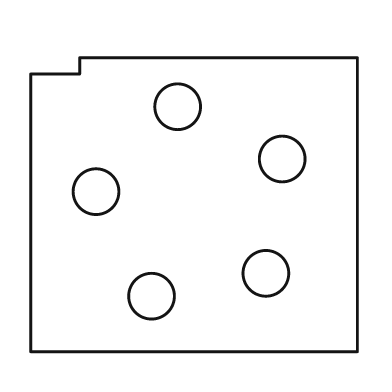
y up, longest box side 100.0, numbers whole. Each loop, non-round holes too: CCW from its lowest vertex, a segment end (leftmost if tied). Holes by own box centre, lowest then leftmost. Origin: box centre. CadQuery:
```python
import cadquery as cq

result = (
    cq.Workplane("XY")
    .moveTo(-50.0, -45.0)
    .lineTo(50.0, -45.0)
    .lineTo(50.0, 45.0)
    .lineTo(-35.0, 45.0)
    .lineTo(-35.0, 40.0)
    .lineTo(-50.0, 40.0)
    .close()
    .moveTo(-13.0, -28.0)
    .circle(7.0)
    .moveTo(22.0, -21.0)
    .circle(7.0)
    .moveTo(-30.0, 4.0)
    .circle(7.0)
    .moveTo(27.0, 14.0)
    .circle(7.0)
    .moveTo(-5.0, 30.0)
    .circle(7.0)
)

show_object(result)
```